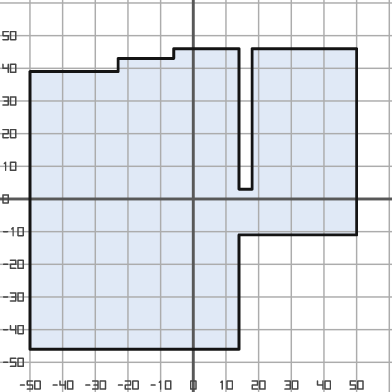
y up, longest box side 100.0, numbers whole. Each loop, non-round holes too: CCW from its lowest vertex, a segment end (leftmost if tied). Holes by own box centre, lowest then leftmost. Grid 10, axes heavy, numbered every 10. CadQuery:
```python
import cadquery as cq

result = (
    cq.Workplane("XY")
    .moveTo(-50.0, -46.0)
    .lineTo(14.0, -46.0)
    .lineTo(14.0, -11.0)
    .lineTo(50.0, -11.0)
    .lineTo(50.0, 46.0)
    .lineTo(18.0, 46.0)
    .lineTo(18.0, 3.0)
    .lineTo(14.0, 3.0)
    .lineTo(14.0, 46.0)
    .lineTo(-6.0, 46.0)
    .lineTo(-6.0, 43.0)
    .lineTo(-23.0, 43.0)
    .lineTo(-23.0, 39.0)
    .lineTo(-50.0, 39.0)
    .close()
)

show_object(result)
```